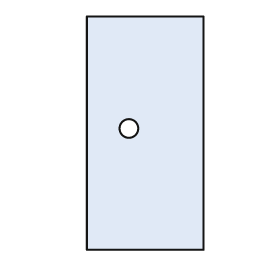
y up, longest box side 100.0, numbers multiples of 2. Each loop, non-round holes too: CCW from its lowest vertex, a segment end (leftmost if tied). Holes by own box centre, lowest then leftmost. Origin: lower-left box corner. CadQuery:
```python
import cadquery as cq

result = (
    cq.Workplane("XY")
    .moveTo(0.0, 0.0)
    .lineTo(50.0, 0.0)
    .lineTo(50.0, 100.0)
    .lineTo(0.0, 100.0)
    .close()
    .moveTo(18.0, 52.0)
    .circle(4.0)
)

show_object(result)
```